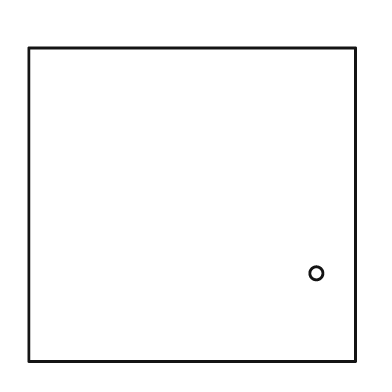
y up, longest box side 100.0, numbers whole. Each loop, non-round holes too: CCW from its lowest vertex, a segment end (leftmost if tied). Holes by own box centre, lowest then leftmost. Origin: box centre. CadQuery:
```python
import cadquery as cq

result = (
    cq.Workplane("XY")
    .moveTo(-50.0, -48.0)
    .lineTo(50.0, -48.0)
    .lineTo(50.0, 48.0)
    .lineTo(-50.0, 48.0)
    .close()
    .moveTo(38.0, -21.0)
    .circle(2.0)
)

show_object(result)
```